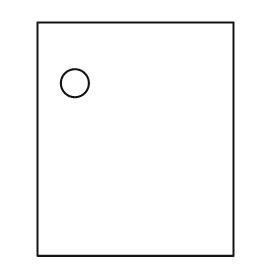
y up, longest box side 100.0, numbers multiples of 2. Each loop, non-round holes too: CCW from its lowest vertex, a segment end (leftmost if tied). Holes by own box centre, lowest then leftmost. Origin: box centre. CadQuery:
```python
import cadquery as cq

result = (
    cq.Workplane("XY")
    .moveTo(-42.0, -50.0)
    .lineTo(42.0, -50.0)
    .lineTo(42.0, 50.0)
    .lineTo(-42.0, 50.0)
    .close()
    .moveTo(-26.0, 24.0)
    .circle(6.0)
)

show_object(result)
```